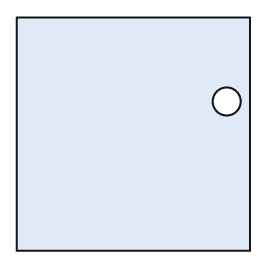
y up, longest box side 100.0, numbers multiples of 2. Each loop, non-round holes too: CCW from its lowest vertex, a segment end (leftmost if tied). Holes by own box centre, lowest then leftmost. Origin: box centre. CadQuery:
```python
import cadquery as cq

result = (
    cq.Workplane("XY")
    .moveTo(-50.0, -50.0)
    .lineTo(50.0, -50.0)
    .lineTo(50.0, 50.0)
    .lineTo(-50.0, 50.0)
    .close()
    .moveTo(40.0, 14.0)
    .circle(6.0)
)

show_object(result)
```